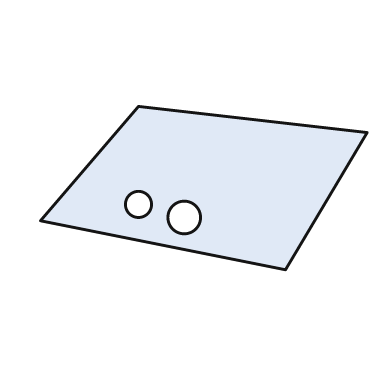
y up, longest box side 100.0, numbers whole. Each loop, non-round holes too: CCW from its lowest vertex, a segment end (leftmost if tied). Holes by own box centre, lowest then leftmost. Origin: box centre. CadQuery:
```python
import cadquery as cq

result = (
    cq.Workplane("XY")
    .moveTo(25.0, -25.0)
    .lineTo(50.0, 17.0)
    .lineTo(-20.0, 25.0)
    .lineTo(-50.0, -10.0)
    .close()
    .moveTo(-6.0, -9.0)
    .circle(5.0)
    .moveTo(-20.0, -5.0)
    .circle(4.0)
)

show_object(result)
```